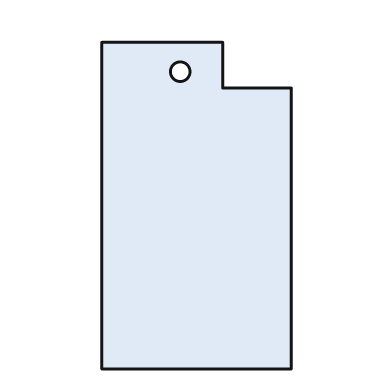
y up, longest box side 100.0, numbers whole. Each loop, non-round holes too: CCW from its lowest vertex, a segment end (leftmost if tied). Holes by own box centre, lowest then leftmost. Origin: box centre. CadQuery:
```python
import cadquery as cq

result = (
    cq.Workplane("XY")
    .moveTo(-29.0, -50.0)
    .lineTo(29.0, -50.0)
    .lineTo(29.0, 36.0)
    .lineTo(8.0, 36.0)
    .lineTo(8.0, 50.0)
    .lineTo(-29.0, 50.0)
    .close()
    .moveTo(-5.0, 41.0)
    .circle(3.0)
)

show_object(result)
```